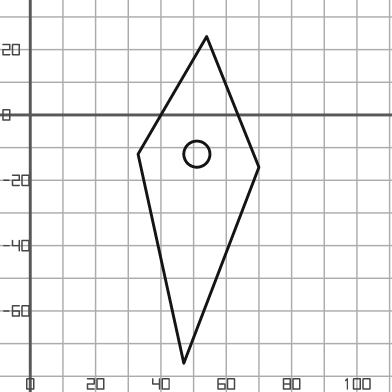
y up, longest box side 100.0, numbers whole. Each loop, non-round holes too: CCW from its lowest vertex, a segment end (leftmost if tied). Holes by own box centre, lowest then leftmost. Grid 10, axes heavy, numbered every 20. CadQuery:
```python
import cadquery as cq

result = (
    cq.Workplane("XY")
    .moveTo(47.0, -76.0)
    .lineTo(70.0, -16.0)
    .lineTo(54.0, 24.0)
    .lineTo(33.0, -12.0)
    .close()
    .moveTo(51.0, -12.0)
    .circle(4.0)
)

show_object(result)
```